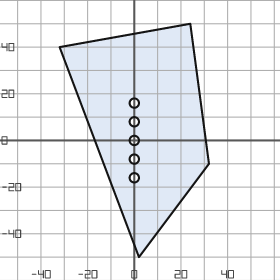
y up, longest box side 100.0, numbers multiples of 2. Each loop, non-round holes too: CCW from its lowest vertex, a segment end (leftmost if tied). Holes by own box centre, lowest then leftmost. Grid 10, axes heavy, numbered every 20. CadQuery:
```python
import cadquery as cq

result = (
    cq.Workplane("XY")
    .moveTo(2.0, -50.0)
    .lineTo(32.0, -10.0)
    .lineTo(24.0, 50.0)
    .lineTo(-32.0, 40.0)
    .close()
    .moveTo(0.0, -16.0)
    .circle(2.0)
    .moveTo(0.0, -8.0)
    .circle(2.0)
    .moveTo(0.0, 0.0)
    .circle(2.0)
    .moveTo(0.0, 8.0)
    .circle(2.0)
    .moveTo(0.0, 16.0)
    .circle(2.0)
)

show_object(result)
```